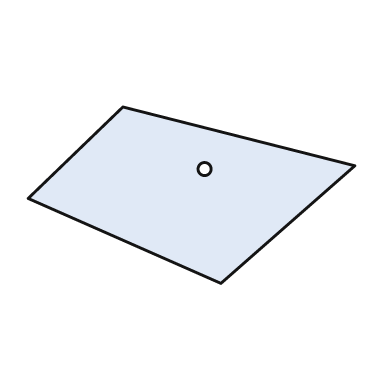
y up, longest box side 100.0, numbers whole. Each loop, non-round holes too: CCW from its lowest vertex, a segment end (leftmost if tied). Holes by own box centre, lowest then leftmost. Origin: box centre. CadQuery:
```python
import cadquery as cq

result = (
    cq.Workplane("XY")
    .moveTo(9.0, -27.0)
    .lineTo(50.0, 9.0)
    .lineTo(-21.0, 27.0)
    .lineTo(-50.0, -1.0)
    .close()
    .moveTo(4.0, 8.0)
    .circle(2.0)
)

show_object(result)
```